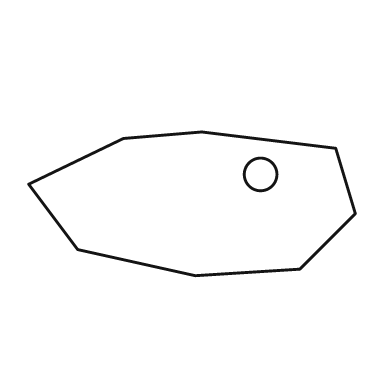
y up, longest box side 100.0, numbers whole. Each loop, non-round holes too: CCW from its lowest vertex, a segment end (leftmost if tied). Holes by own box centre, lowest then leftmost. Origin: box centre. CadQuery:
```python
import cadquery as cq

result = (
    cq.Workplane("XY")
    .moveTo(1.0, -22.0)
    .lineTo(33.0, -20.0)
    .lineTo(50.0, -3.0)
    .lineTo(44.0, 17.0)
    .lineTo(3.0, 22.0)
    .lineTo(-21.0, 20.0)
    .lineTo(-50.0, 6.0)
    .lineTo(-35.0, -14.0)
    .close()
    .moveTo(21.0, 9.0)
    .circle(5.0)
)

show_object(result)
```